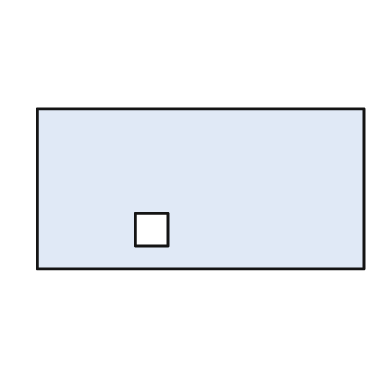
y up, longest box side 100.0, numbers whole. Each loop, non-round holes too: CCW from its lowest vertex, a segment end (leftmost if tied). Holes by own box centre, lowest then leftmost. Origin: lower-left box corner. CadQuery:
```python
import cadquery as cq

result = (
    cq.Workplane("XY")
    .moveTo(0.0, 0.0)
    .lineTo(100.0, 0.0)
    .lineTo(100.0, 49.0)
    .lineTo(0.0, 49.0)
    .close()
    .moveTo(30.0, 7.0)
    .lineTo(40.0, 7.0)
    .lineTo(40.0, 17.0)
    .lineTo(30.0, 17.0)
    .close()
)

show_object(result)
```